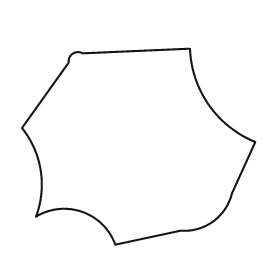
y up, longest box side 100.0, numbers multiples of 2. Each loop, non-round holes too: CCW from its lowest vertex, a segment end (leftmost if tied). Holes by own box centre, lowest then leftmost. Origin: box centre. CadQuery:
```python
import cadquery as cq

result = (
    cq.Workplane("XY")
    .moveTo(-10.0, -42.0)
    .lineTo(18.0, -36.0)
    .threePointArc((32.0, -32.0), (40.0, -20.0))
    .lineTo(50.0, 2.0)
    .threePointArc((30.0, 18.0), (22.0, 42.0))
    .lineTo(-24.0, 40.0)
    .threePointArc((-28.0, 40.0), (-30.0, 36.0))
    .lineTo(-50.0, 8.0)
    .threePointArc((-42.0, -10.0), (-44.0, -30.0))
    .threePointArc((-24.0, -28.0), (-10.0, -42.0))
    .close()
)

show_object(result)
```